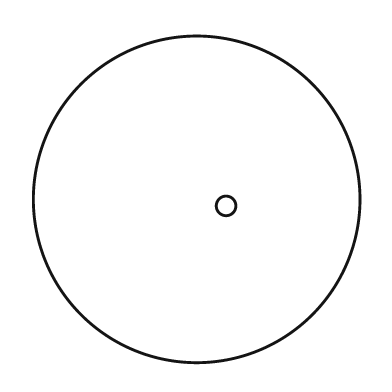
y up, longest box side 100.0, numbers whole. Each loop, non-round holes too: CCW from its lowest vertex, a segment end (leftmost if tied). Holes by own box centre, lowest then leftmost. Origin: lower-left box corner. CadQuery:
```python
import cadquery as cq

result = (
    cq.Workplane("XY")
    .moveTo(50.0, 50.0)
    .circle(50.0)
    .moveTo(59.0, 48.0)
    .circle(3.0)
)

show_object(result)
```